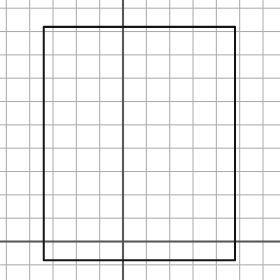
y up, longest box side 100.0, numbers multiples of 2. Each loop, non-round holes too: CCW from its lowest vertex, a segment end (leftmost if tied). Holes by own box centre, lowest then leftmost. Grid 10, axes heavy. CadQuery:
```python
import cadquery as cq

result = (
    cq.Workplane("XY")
    .moveTo(-34.0, -8.0)
    .lineTo(48.0, -8.0)
    .lineTo(48.0, 92.0)
    .lineTo(-34.0, 92.0)
    .close()
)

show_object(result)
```